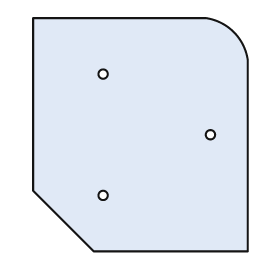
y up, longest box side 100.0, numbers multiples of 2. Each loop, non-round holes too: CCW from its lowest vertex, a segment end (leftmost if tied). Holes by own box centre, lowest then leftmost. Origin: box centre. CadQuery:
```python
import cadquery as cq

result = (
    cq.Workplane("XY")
    .moveTo(-20.0, -50.0)
    .lineTo(46.0, -50.0)
    .lineTo(46.0, 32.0)
    .threePointArc((40.0, 44.0), (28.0, 50.0))
    .lineTo(-46.0, 50.0)
    .lineTo(-46.0, -24.0)
    .close()
    .moveTo(-16.0, -26.0)
    .circle(2.0)
    .moveTo(30.0, 0.0)
    .circle(2.0)
    .moveTo(-16.0, 26.0)
    .circle(2.0)
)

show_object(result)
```